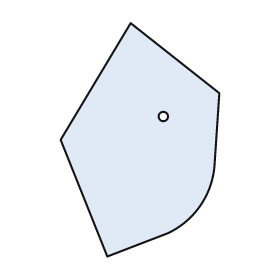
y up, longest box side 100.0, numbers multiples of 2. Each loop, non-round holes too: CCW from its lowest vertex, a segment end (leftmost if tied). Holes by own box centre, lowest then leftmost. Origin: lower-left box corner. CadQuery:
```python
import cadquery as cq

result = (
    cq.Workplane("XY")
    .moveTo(20.0, 0.0)
    .lineTo(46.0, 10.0)
    .threePointArc((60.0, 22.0), (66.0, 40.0))
    .lineTo(68.0, 70.0)
    .lineTo(30.0, 100.0)
    .lineTo(0.0, 50.0)
    .close()
    .moveTo(44.0, 60.0)
    .circle(2.0)
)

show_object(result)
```